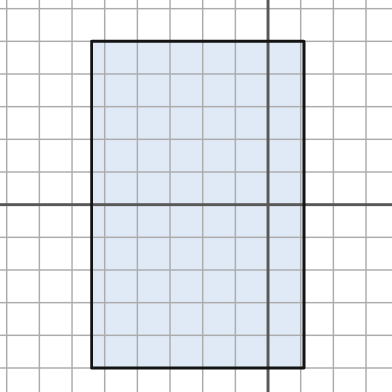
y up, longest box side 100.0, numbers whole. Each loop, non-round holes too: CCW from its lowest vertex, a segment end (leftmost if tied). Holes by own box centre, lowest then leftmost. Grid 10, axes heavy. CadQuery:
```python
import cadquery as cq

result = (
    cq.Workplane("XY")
    .moveTo(-54.0, -50.0)
    .lineTo(11.0, -50.0)
    .lineTo(11.0, 50.0)
    .lineTo(-54.0, 50.0)
    .close()
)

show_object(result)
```